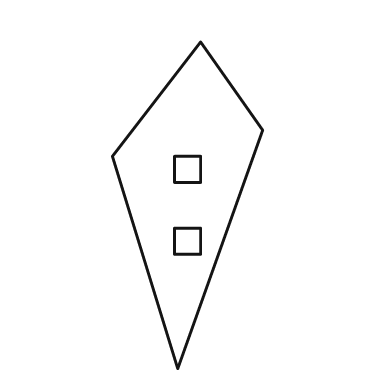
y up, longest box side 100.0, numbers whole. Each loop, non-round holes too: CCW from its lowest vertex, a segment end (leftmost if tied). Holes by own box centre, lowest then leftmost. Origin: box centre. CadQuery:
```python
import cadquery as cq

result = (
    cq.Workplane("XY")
    .moveTo(-3.0, -50.0)
    .lineTo(23.0, 23.0)
    .lineTo(4.0, 50.0)
    .lineTo(-23.0, 15.0)
    .close()
    .moveTo(-4.0, -15.0)
    .lineTo(4.0, -15.0)
    .lineTo(4.0, -7.0)
    .lineTo(-4.0, -7.0)
    .close()
    .moveTo(-4.0, 7.0)
    .lineTo(4.0, 7.0)
    .lineTo(4.0, 15.0)
    .lineTo(-4.0, 15.0)
    .close()
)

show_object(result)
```